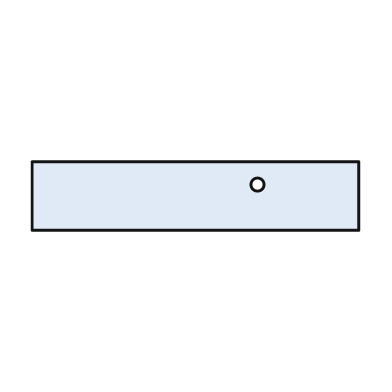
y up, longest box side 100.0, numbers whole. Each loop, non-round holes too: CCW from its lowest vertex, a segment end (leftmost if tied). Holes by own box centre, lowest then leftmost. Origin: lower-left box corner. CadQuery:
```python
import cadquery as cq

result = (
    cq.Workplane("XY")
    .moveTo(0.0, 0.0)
    .lineTo(100.0, 0.0)
    .lineTo(100.0, 21.0)
    .lineTo(0.0, 21.0)
    .close()
    .moveTo(69.0, 14.0)
    .circle(2.0)
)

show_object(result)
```